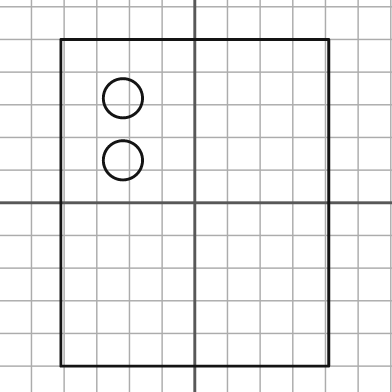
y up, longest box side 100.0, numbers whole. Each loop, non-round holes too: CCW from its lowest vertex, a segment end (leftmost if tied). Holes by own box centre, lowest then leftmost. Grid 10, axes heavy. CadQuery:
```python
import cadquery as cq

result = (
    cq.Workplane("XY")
    .moveTo(-41.0, -50.0)
    .lineTo(41.0, -50.0)
    .lineTo(41.0, 50.0)
    .lineTo(-41.0, 50.0)
    .close()
    .moveTo(-22.0, 13.0)
    .circle(6.0)
    .moveTo(-22.0, 32.0)
    .circle(6.0)
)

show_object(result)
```